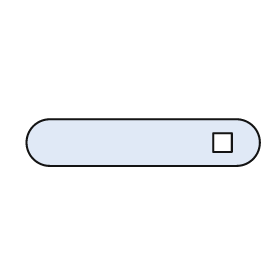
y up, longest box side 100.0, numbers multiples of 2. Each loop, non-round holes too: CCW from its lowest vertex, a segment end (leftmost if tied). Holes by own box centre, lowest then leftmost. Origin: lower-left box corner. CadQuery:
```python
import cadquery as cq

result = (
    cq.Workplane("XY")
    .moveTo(10.0, 0.0)
    .lineTo(90.0, 0.0)
    .threePointArc((100.0, 10.0), (90.0, 20.0))
    .lineTo(10.0, 20.0)
    .threePointArc((0.0, 10.0), (10.0, 0.0))
    .close()
    .moveTo(80.0, 6.0)
    .lineTo(88.0, 6.0)
    .lineTo(88.0, 14.0)
    .lineTo(80.0, 14.0)
    .close()
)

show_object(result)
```